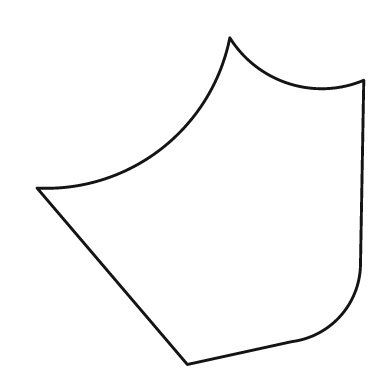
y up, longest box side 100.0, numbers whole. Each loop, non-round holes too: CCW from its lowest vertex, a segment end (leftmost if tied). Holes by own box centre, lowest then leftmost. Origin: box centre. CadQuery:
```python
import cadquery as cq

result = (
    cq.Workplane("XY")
    .moveTo(-4.0, -50.0)
    .lineTo(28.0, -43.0)
    .threePointArc((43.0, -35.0), (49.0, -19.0))
    .lineTo(50.0, 37.0)
    .threePointArc((27.0, 36.0), (9.0, 50.0))
    .threePointArc((-12.0, 16.0), (-50.0, 4.0))
    .close()
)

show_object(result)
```